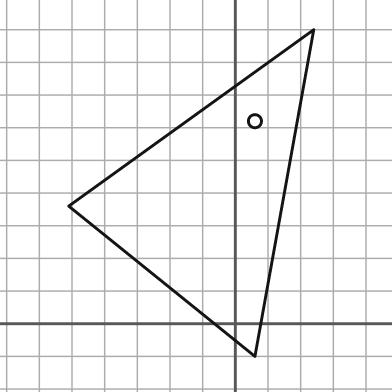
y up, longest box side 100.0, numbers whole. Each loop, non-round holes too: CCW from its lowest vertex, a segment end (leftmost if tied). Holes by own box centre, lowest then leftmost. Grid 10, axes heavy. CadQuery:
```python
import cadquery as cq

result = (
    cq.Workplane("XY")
    .moveTo(6.0, -10.0)
    .lineTo(24.0, 90.0)
    .lineTo(-51.0, 36.0)
    .close()
    .moveTo(6.0, 62.0)
    .circle(2.0)
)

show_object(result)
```